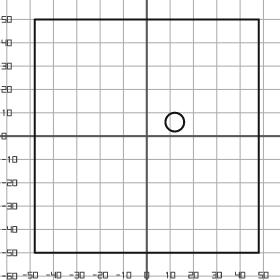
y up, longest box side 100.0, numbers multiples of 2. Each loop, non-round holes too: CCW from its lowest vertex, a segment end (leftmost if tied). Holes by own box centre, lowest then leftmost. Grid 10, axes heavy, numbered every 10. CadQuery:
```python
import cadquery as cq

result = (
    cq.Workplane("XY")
    .moveTo(-48.0, -50.0)
    .lineTo(48.0, -50.0)
    .lineTo(48.0, 50.0)
    .lineTo(-48.0, 50.0)
    .close()
    .moveTo(12.0, 6.0)
    .circle(4.0)
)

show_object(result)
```